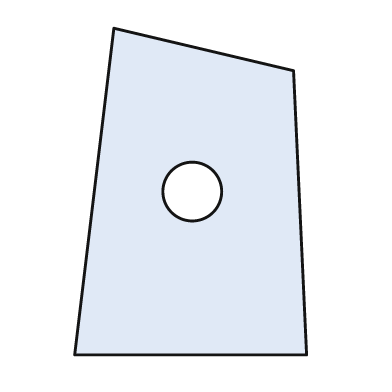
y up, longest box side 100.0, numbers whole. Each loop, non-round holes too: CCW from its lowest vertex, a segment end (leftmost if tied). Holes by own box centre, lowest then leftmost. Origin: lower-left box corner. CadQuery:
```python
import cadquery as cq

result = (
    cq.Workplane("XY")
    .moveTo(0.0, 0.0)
    .lineTo(71.0, 0.0)
    .lineTo(67.0, 87.0)
    .lineTo(12.0, 100.0)
    .close()
    .moveTo(36.0, 50.0)
    .circle(9.0)
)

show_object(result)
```